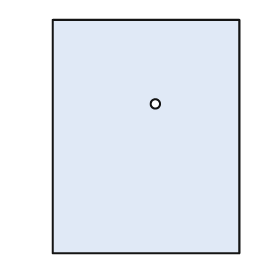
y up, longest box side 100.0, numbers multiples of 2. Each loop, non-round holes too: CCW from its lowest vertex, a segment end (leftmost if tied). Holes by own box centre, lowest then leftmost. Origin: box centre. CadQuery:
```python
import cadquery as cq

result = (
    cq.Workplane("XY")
    .moveTo(-40.0, -50.0)
    .lineTo(40.0, -50.0)
    .lineTo(40.0, 50.0)
    .lineTo(-40.0, 50.0)
    .close()
    .moveTo(4.0, 14.0)
    .circle(2.0)
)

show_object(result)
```